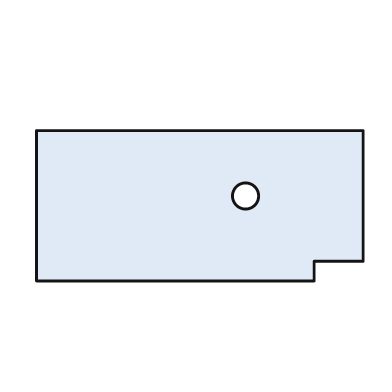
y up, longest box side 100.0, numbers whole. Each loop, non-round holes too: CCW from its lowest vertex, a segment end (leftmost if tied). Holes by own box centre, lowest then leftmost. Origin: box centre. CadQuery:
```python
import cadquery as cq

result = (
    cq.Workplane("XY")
    .moveTo(-50.0, -23.0)
    .lineTo(35.0, -23.0)
    .lineTo(35.0, -17.0)
    .lineTo(50.0, -17.0)
    .lineTo(50.0, 23.0)
    .lineTo(-50.0, 23.0)
    .close()
    .moveTo(14.0, 3.0)
    .circle(4.0)
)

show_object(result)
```